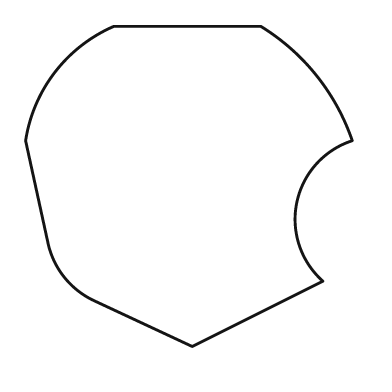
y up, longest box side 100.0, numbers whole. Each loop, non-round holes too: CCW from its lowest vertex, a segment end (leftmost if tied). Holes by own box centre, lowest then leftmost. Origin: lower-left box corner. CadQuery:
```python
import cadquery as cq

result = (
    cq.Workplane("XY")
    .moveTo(51.0, 0.0)
    .lineTo(91.0, 20.0)
    .threePointArc((83.0, 44.0), (100.0, 63.0))
    .threePointArc((89.0, 83.0), (72.0, 98.0))
    .lineTo(27.0, 98.0)
    .threePointArc((9.0, 84.0), (0.0, 63.0))
    .lineTo(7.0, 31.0)
    .threePointArc((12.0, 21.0), (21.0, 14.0))
    .close()
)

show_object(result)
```